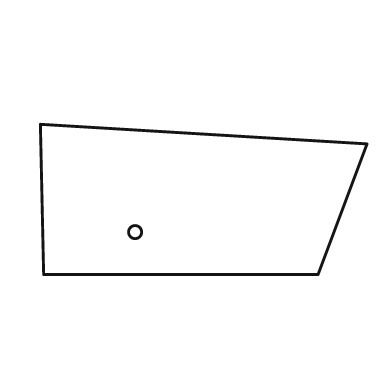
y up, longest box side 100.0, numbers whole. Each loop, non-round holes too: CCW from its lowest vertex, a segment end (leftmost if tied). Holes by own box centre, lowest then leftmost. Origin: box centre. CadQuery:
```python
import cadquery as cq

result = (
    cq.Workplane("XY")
    .moveTo(-49.0, -23.0)
    .lineTo(35.0, -23.0)
    .lineTo(50.0, 17.0)
    .lineTo(-50.0, 23.0)
    .close()
    .moveTo(-21.0, -10.0)
    .circle(2.0)
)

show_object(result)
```